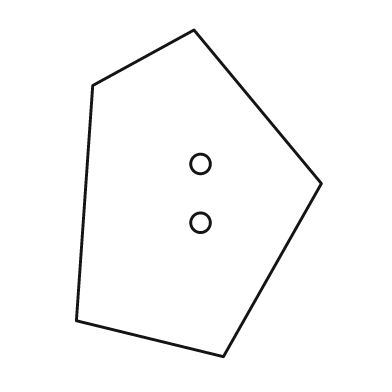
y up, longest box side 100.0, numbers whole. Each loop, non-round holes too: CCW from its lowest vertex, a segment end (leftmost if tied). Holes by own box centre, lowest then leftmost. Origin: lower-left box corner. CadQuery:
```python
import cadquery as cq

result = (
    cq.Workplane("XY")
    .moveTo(45.0, 0.0)
    .lineTo(75.0, 53.0)
    .lineTo(36.0, 100.0)
    .lineTo(5.0, 83.0)
    .lineTo(0.0, 11.0)
    .close()
    .moveTo(38.0, 41.0)
    .circle(3.0)
    .moveTo(38.0, 59.0)
    .circle(3.0)
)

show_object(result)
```